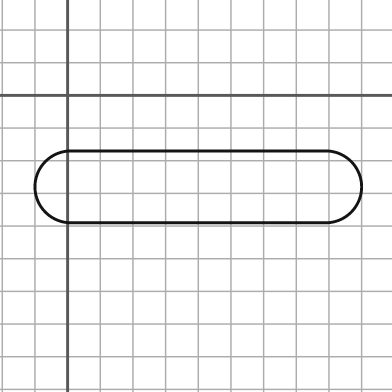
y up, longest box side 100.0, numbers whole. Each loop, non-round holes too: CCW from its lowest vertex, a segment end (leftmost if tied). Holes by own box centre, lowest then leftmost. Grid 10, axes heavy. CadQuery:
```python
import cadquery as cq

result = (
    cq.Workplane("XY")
    .moveTo(1.0, -39.0)
    .lineTo(79.0, -39.0)
    .threePointArc((90.0, -28.0), (79.0, -17.0))
    .lineTo(1.0, -17.0)
    .threePointArc((-10.0, -28.0), (1.0, -39.0))
    .close()
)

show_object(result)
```